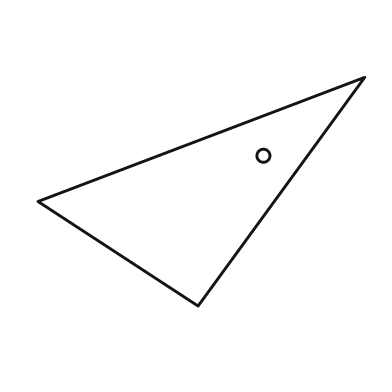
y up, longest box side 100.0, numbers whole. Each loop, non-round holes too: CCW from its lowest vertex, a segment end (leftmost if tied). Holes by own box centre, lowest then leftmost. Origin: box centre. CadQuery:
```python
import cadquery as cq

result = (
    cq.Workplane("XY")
    .moveTo(-1.0, -35.0)
    .lineTo(50.0, 35.0)
    .lineTo(-50.0, -3.0)
    .close()
    .moveTo(19.0, 11.0)
    .circle(2.0)
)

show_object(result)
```